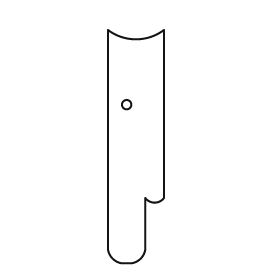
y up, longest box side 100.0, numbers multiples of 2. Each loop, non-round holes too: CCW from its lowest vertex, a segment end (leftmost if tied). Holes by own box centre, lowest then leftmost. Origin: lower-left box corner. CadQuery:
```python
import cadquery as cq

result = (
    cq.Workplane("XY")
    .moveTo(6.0, 0.0)
    .lineTo(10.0, 0.0)
    .threePointArc((14.0, 2.0), (16.0, 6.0))
    .lineTo(16.0, 28.0)
    .threePointArc((20.0, 26.0), (24.0, 28.0))
    .lineTo(24.0, 100.0)
    .threePointArc((12.0, 96.0), (0.0, 100.0))
    .lineTo(0.0, 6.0)
    .threePointArc((2.0, 2.0), (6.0, 0.0))
    .close()
    .moveTo(8.0, 68.0)
    .circle(2.0)
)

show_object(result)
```